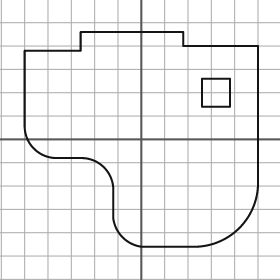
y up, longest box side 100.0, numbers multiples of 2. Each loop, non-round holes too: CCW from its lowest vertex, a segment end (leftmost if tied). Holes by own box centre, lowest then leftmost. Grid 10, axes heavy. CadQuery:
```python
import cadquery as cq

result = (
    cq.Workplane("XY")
    .moveTo(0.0, -46.0)
    .lineTo(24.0, -46.0)
    .threePointArc((42.0, -38.0), (50.0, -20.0))
    .lineTo(50.0, 40.0)
    .lineTo(18.0, 40.0)
    .lineTo(18.0, 46.0)
    .lineTo(-26.0, 46.0)
    .lineTo(-26.0, 38.0)
    .lineTo(-50.0, 38.0)
    .lineTo(-50.0, 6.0)
    .threePointArc((-46.0, -4.0), (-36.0, -8.0))
    .lineTo(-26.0, -8.0)
    .threePointArc((-16.0, -12.0), (-12.0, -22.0))
    .lineTo(-12.0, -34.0)
    .threePointArc((-8.0, -42.0), (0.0, -46.0))
    .close()
    .moveTo(26.0, 14.0)
    .lineTo(38.0, 14.0)
    .lineTo(38.0, 26.0)
    .lineTo(26.0, 26.0)
    .close()
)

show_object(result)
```